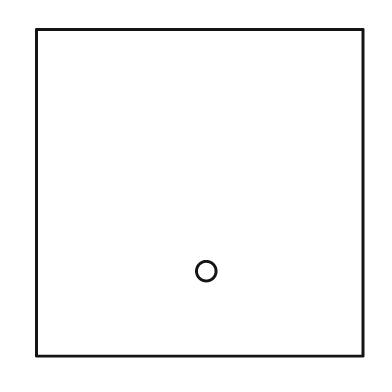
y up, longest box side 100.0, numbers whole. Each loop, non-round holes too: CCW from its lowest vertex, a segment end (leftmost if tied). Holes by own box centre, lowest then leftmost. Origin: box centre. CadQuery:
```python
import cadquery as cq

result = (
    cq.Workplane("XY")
    .moveTo(-50.0, -50.0)
    .lineTo(50.0, -50.0)
    .lineTo(50.0, 50.0)
    .lineTo(-50.0, 50.0)
    .close()
    .moveTo(2.0, -24.0)
    .circle(3.0)
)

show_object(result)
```